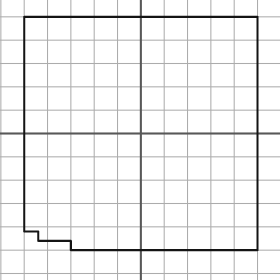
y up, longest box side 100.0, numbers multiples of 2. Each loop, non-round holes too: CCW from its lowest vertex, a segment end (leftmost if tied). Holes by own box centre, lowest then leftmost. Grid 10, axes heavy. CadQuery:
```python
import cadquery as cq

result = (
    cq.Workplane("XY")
    .moveTo(-30.0, -50.0)
    .lineTo(50.0, -50.0)
    .lineTo(50.0, 50.0)
    .lineTo(-50.0, 50.0)
    .lineTo(-50.0, -42.0)
    .lineTo(-44.0, -42.0)
    .lineTo(-44.0, -46.0)
    .lineTo(-30.0, -46.0)
    .close()
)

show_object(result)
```